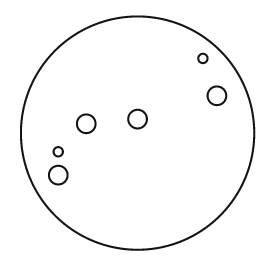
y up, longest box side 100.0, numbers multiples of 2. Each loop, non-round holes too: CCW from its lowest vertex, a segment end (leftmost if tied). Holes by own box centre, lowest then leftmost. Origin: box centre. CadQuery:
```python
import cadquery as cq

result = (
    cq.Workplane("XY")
    .moveTo(0.0, 0.0)
    .circle(50.0)
    .moveTo(-34.0, -18.0)
    .circle(4.0)
    .moveTo(-34.0, -8.0)
    .circle(2.0)
    .moveTo(-22.0, 4.0)
    .circle(4.0)
    .moveTo(0.0, 6.0)
    .circle(4.0)
    .moveTo(34.0, 16.0)
    .circle(4.0)
    .moveTo(28.0, 32.0)
    .circle(2.0)
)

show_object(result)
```